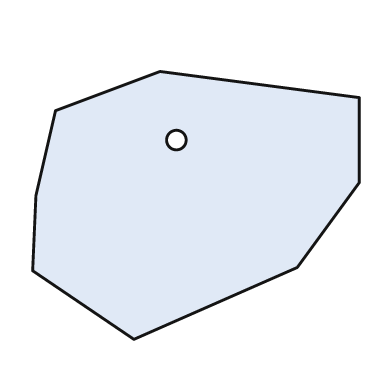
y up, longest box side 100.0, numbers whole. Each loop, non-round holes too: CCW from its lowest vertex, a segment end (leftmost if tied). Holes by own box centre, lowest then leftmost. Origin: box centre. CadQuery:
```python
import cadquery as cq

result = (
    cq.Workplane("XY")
    .moveTo(-19.0, -41.0)
    .lineTo(31.0, -19.0)
    .lineTo(50.0, 7.0)
    .lineTo(50.0, 33.0)
    .lineTo(-11.0, 41.0)
    .lineTo(-43.0, 29.0)
    .lineTo(-49.0, 3.0)
    .lineTo(-50.0, -20.0)
    .close()
    .moveTo(-6.0, 20.0)
    .circle(3.0)
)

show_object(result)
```